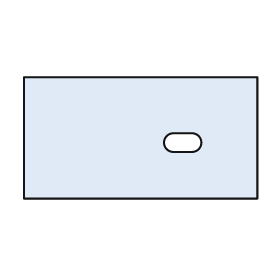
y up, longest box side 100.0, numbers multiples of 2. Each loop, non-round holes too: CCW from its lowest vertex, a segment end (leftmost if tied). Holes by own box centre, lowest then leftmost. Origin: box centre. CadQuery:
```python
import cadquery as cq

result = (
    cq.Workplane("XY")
    .moveTo(-50.0, -26.0)
    .lineTo(50.0, -26.0)
    .lineTo(50.0, 26.0)
    .lineTo(-50.0, 26.0)
    .close()
    .moveTo(14.0, -6.0)
    .lineTo(22.0, -6.0)
    .threePointArc((26.0, -2.0), (22.0, 2.0))
    .lineTo(14.0, 2.0)
    .threePointArc((10.0, -2.0), (14.0, -6.0))
    .close()
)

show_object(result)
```